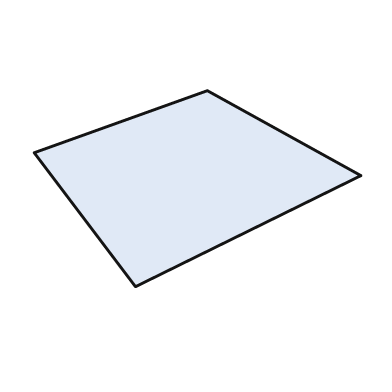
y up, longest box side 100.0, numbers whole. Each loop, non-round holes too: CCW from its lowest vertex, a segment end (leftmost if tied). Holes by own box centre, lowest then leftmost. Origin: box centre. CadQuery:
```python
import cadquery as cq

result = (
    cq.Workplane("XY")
    .moveTo(-19.0, -30.0)
    .lineTo(50.0, 4.0)
    .lineTo(3.0, 30.0)
    .lineTo(-50.0, 11.0)
    .close()
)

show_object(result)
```